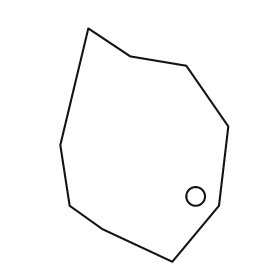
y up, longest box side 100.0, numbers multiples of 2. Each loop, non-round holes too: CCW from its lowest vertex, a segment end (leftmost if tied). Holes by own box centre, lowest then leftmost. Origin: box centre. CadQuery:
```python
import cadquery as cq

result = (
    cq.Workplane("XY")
    .moveTo(12.0, -50.0)
    .lineTo(32.0, -26.0)
    .lineTo(36.0, 8.0)
    .lineTo(18.0, 34.0)
    .lineTo(-6.0, 38.0)
    .lineTo(-24.0, 50.0)
    .lineTo(-36.0, 0.0)
    .lineTo(-32.0, -26.0)
    .lineTo(-18.0, -36.0)
    .close()
    .moveTo(22.0, -22.0)
    .circle(4.0)
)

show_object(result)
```